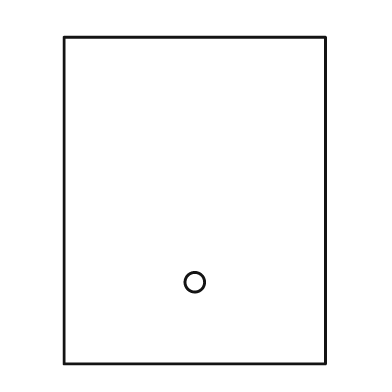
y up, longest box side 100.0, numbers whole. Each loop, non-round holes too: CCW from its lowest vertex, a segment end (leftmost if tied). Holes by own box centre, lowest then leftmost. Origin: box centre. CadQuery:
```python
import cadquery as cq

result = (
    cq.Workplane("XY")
    .moveTo(-40.0, -50.0)
    .lineTo(40.0, -50.0)
    .lineTo(40.0, 50.0)
    .lineTo(-40.0, 50.0)
    .close()
    .moveTo(0.0, -25.0)
    .circle(3.0)
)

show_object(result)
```